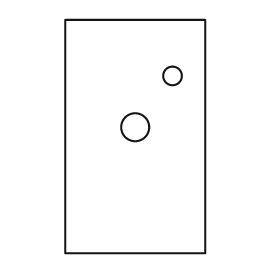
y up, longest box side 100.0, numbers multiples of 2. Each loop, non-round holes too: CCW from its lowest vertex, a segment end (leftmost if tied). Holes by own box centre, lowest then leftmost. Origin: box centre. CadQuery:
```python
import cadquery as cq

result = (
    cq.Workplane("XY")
    .moveTo(-30.0, -50.0)
    .lineTo(30.0, -50.0)
    .lineTo(30.0, 50.0)
    .lineTo(-30.0, 50.0)
    .close()
    .moveTo(0.0, 4.0)
    .circle(6.0)
    .moveTo(16.0, 26.0)
    .circle(4.0)
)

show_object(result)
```